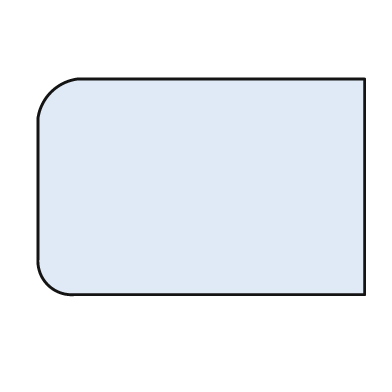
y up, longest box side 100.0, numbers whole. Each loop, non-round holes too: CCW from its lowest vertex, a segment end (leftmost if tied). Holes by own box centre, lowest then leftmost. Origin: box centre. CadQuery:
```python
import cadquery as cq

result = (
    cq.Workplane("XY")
    .moveTo(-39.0, -33.0)
    .lineTo(50.0, -33.0)
    .lineTo(50.0, 33.0)
    .lineTo(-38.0, 33.0)
    .threePointArc((-46.0, 29.0), (-50.0, 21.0))
    .lineTo(-50.0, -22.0)
    .threePointArc((-47.0, -30.0), (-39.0, -33.0))
    .close()
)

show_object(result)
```